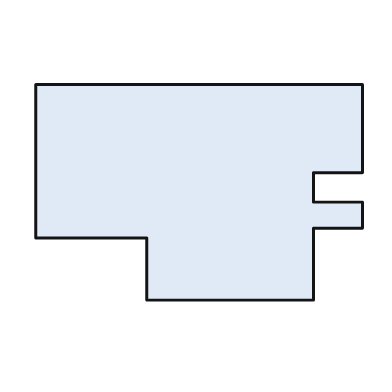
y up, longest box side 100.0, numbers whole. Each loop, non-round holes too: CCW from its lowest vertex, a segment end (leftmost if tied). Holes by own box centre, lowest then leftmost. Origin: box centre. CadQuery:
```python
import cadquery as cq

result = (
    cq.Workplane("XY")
    .moveTo(-16.0, -33.0)
    .lineTo(35.0, -33.0)
    .lineTo(35.0, -11.0)
    .lineTo(50.0, -11.0)
    .lineTo(50.0, -3.0)
    .lineTo(35.0, -3.0)
    .lineTo(35.0, 6.0)
    .lineTo(50.0, 6.0)
    .lineTo(50.0, 33.0)
    .lineTo(-50.0, 33.0)
    .lineTo(-50.0, -14.0)
    .lineTo(-16.0, -14.0)
    .close()
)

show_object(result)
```